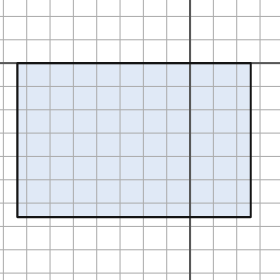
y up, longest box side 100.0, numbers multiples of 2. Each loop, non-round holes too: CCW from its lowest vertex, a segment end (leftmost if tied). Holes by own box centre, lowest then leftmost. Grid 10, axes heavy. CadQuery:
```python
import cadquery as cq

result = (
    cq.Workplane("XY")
    .moveTo(-74.0, -66.0)
    .lineTo(26.0, -66.0)
    .lineTo(26.0, 0.0)
    .lineTo(-74.0, 0.0)
    .close()
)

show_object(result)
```